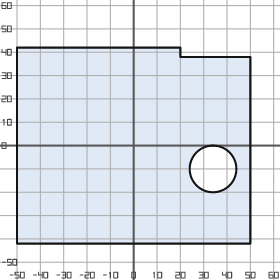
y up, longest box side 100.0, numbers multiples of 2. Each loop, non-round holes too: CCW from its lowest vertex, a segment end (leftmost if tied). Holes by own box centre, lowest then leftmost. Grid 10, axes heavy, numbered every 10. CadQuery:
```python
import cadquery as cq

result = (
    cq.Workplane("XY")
    .moveTo(-50.0, -42.0)
    .lineTo(50.0, -42.0)
    .lineTo(50.0, 38.0)
    .lineTo(20.0, 38.0)
    .lineTo(20.0, 42.0)
    .lineTo(-50.0, 42.0)
    .close()
    .moveTo(34.0, -10.0)
    .circle(10.0)
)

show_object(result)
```